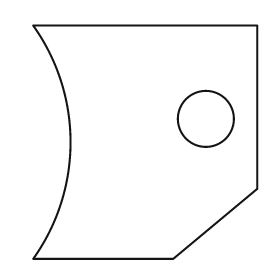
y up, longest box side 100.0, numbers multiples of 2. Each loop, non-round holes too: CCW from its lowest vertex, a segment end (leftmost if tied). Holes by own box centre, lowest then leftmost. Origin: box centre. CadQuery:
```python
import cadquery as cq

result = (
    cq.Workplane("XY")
    .moveTo(-48.0, -50.0)
    .lineTo(12.0, -50.0)
    .lineTo(48.0, -20.0)
    .lineTo(48.0, 50.0)
    .lineTo(-48.0, 50.0)
    .threePointArc((-32.0, 0.0), (-48.0, -50.0))
    .close()
    .moveTo(26.0, 10.0)
    .circle(12.0)
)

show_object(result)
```